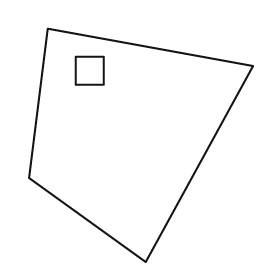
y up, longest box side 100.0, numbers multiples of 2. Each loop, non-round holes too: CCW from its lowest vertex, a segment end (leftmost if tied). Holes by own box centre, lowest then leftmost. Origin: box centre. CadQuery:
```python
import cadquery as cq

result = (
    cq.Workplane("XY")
    .moveTo(2.0, -50.0)
    .lineTo(48.0, 34.0)
    .lineTo(-40.0, 50.0)
    .lineTo(-48.0, -14.0)
    .close()
    .moveTo(-28.0, 26.0)
    .lineTo(-16.0, 26.0)
    .lineTo(-16.0, 38.0)
    .lineTo(-28.0, 38.0)
    .close()
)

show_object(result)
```